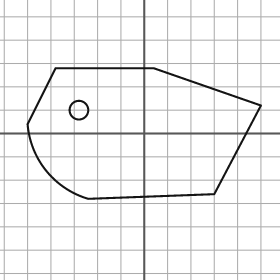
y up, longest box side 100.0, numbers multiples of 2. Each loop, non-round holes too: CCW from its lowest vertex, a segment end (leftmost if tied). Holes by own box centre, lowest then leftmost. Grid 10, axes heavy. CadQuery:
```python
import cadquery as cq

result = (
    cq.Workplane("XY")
    .moveTo(-24.0, -28.0)
    .lineTo(30.0, -26.0)
    .lineTo(50.0, 12.0)
    .lineTo(4.0, 28.0)
    .lineTo(-38.0, 28.0)
    .lineTo(-50.0, 4.0)
    .threePointArc((-42.0, -16.0), (-24.0, -28.0))
    .close()
    .moveTo(-28.0, 10.0)
    .circle(4.0)
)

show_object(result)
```